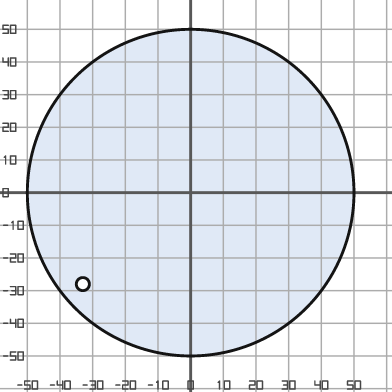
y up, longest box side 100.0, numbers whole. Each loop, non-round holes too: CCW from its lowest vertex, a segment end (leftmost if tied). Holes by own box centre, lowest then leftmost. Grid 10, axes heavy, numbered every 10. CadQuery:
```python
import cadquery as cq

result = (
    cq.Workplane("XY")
    .moveTo(0.0, 0.0)
    .circle(50.0)
    .moveTo(-33.0, -28.0)
    .circle(2.0)
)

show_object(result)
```